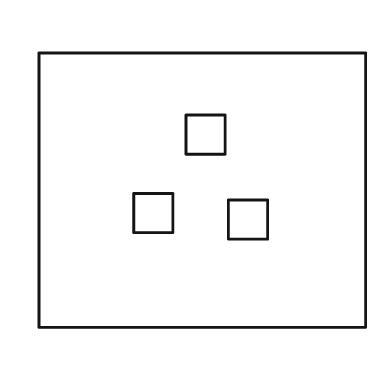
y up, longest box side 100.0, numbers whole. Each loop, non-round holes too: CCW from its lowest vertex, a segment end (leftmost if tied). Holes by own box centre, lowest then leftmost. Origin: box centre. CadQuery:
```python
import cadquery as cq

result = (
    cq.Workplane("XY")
    .moveTo(-50.0, -42.0)
    .lineTo(50.0, -42.0)
    .lineTo(50.0, 42.0)
    .lineTo(-50.0, 42.0)
    .close()
    .moveTo(8.0, -15.0)
    .lineTo(20.0, -15.0)
    .lineTo(20.0, -3.0)
    .lineTo(8.0, -3.0)
    .close()
    .moveTo(-21.0, -13.0)
    .lineTo(-9.0, -13.0)
    .lineTo(-9.0, -1.0)
    .lineTo(-21.0, -1.0)
    .close()
    .moveTo(-5.0, 11.0)
    .lineTo(7.0, 11.0)
    .lineTo(7.0, 23.0)
    .lineTo(-5.0, 23.0)
    .close()
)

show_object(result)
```